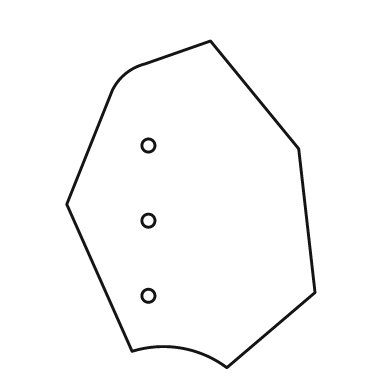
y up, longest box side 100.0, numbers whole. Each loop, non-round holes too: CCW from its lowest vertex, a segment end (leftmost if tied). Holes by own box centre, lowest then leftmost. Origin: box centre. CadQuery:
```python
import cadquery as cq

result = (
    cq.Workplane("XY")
    .moveTo(11.0, -50.0)
    .lineTo(38.0, -27.0)
    .lineTo(33.0, 17.0)
    .lineTo(6.0, 50.0)
    .lineTo(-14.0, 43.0)
    .threePointArc((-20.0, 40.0), (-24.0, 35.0))
    .lineTo(-38.0, 0.0)
    .lineTo(-18.0, -45.0)
    .threePointArc((-3.0, -44.0), (11.0, -50.0))
    .close()
    .moveTo(-13.0, -28.0)
    .circle(2.0)
    .moveTo(-13.0, -5.0)
    .circle(2.0)
    .moveTo(-13.0, 18.0)
    .circle(2.0)
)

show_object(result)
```